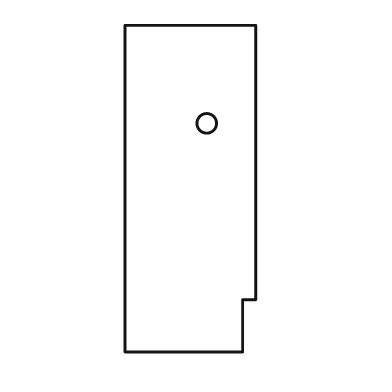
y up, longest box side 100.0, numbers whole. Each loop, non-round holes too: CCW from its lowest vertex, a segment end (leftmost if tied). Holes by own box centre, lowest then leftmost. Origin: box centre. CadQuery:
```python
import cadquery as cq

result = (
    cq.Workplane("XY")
    .moveTo(-20.0, -50.0)
    .lineTo(16.0, -50.0)
    .lineTo(16.0, -34.0)
    .lineTo(20.0, -34.0)
    .lineTo(20.0, 50.0)
    .lineTo(-20.0, 50.0)
    .close()
    .moveTo(5.0, 20.0)
    .circle(3.0)
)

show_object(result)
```